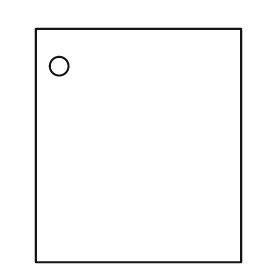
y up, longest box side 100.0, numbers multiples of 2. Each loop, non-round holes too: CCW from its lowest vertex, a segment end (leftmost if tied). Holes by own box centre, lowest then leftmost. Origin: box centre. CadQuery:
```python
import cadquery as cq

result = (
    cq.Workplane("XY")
    .moveTo(-44.0, -50.0)
    .lineTo(44.0, -50.0)
    .lineTo(44.0, 50.0)
    .lineTo(-44.0, 50.0)
    .close()
    .moveTo(-34.0, 34.0)
    .circle(4.0)
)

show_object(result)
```